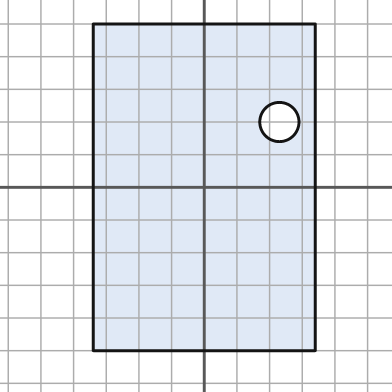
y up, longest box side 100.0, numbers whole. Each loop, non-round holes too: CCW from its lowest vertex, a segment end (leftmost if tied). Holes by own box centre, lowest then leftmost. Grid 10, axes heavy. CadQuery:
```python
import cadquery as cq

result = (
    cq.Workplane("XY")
    .moveTo(-34.0, -50.0)
    .lineTo(34.0, -50.0)
    .lineTo(34.0, 50.0)
    .lineTo(-34.0, 50.0)
    .close()
    .moveTo(23.0, 20.0)
    .circle(6.0)
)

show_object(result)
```